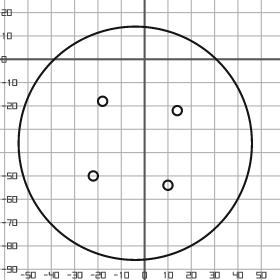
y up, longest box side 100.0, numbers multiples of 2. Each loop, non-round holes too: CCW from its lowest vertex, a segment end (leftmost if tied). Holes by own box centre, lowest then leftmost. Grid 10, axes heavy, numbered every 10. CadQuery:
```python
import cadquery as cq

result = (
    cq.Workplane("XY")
    .moveTo(-4.0, -36.0)
    .circle(50.0)
    .moveTo(10.0, -54.0)
    .circle(2.0)
    .moveTo(-22.0, -50.0)
    .circle(2.0)
    .moveTo(14.0, -22.0)
    .circle(2.0)
    .moveTo(-18.0, -18.0)
    .circle(2.0)
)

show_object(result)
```